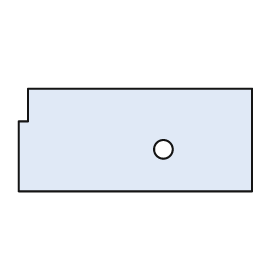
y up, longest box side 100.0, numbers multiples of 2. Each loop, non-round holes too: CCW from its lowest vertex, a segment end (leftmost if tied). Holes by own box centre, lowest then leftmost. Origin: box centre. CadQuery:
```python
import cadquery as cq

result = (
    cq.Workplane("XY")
    .moveTo(-50.0, -22.0)
    .lineTo(50.0, -22.0)
    .lineTo(50.0, 22.0)
    .lineTo(-46.0, 22.0)
    .lineTo(-46.0, 8.0)
    .lineTo(-50.0, 8.0)
    .close()
    .moveTo(12.0, -4.0)
    .circle(4.0)
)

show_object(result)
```